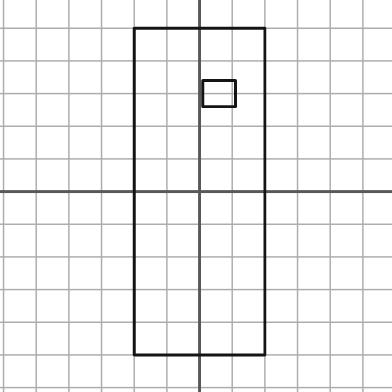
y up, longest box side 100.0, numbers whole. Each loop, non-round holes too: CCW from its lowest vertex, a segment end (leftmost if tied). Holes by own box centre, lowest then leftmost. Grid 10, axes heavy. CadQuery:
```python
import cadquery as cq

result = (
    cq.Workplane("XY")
    .moveTo(-20.0, -50.0)
    .lineTo(20.0, -50.0)
    .lineTo(20.0, 50.0)
    .lineTo(-20.0, 50.0)
    .close()
    .moveTo(1.0, 26.0)
    .lineTo(11.0, 26.0)
    .lineTo(11.0, 34.0)
    .lineTo(1.0, 34.0)
    .close()
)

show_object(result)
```